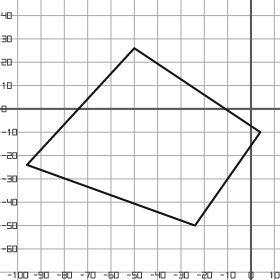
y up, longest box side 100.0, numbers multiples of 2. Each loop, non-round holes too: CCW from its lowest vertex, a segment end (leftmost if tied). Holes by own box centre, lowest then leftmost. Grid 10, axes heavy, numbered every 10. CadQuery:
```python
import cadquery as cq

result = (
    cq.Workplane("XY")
    .moveTo(-24.0, -50.0)
    .lineTo(4.0, -10.0)
    .lineTo(-50.0, 26.0)
    .lineTo(-96.0, -24.0)
    .close()
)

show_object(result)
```